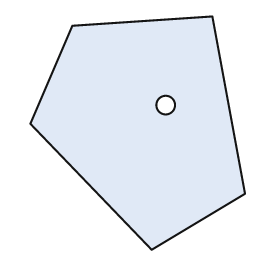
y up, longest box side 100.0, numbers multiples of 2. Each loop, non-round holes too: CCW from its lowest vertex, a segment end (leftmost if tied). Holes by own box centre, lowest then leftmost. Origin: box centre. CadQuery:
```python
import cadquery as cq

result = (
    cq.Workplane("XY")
    .moveTo(6.0, -50.0)
    .lineTo(46.0, -26.0)
    .lineTo(32.0, 50.0)
    .lineTo(-28.0, 46.0)
    .lineTo(-46.0, 4.0)
    .close()
    .moveTo(12.0, 12.0)
    .circle(4.0)
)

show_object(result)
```